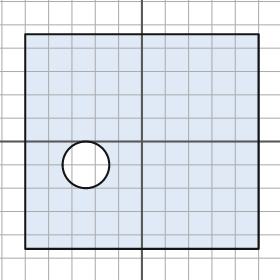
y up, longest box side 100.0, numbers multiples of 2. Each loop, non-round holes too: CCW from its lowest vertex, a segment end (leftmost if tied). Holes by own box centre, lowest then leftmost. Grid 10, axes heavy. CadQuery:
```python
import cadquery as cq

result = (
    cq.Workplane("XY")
    .moveTo(-50.0, -46.0)
    .lineTo(50.0, -46.0)
    .lineTo(50.0, 46.0)
    .lineTo(-50.0, 46.0)
    .close()
    .moveTo(-24.0, -10.0)
    .circle(10.0)
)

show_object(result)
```